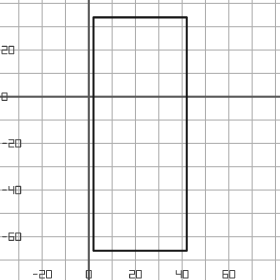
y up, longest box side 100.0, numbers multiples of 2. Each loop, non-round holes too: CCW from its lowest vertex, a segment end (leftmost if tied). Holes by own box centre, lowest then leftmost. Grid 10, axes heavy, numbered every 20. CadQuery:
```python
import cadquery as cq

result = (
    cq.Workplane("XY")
    .moveTo(2.0, -66.0)
    .lineTo(42.0, -66.0)
    .lineTo(42.0, 34.0)
    .lineTo(2.0, 34.0)
    .close()
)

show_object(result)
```